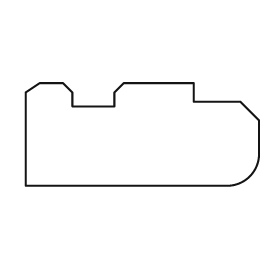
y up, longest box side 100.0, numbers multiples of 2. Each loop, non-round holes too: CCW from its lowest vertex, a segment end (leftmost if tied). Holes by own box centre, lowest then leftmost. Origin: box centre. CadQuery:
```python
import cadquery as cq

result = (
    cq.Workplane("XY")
    .moveTo(-50.0, -22.0)
    .lineTo(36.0, -22.0)
    .threePointArc((46.0, -18.0), (50.0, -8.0))
    .lineTo(50.0, 6.0)
    .lineTo(42.0, 14.0)
    .lineTo(22.0, 14.0)
    .lineTo(22.0, 22.0)
    .lineTo(-8.0, 22.0)
    .lineTo(-12.0, 18.0)
    .lineTo(-12.0, 12.0)
    .lineTo(-30.0, 12.0)
    .lineTo(-30.0, 18.0)
    .lineTo(-34.0, 22.0)
    .lineTo(-44.0, 22.0)
    .lineTo(-50.0, 18.0)
    .close()
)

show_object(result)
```